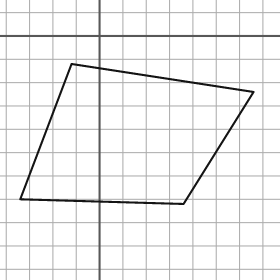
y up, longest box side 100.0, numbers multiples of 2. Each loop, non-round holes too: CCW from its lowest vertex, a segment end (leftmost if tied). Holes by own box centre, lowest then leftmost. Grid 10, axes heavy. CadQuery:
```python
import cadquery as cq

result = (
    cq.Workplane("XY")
    .moveTo(36.0, -72.0)
    .lineTo(66.0, -24.0)
    .lineTo(-12.0, -12.0)
    .lineTo(-34.0, -70.0)
    .close()
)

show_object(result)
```